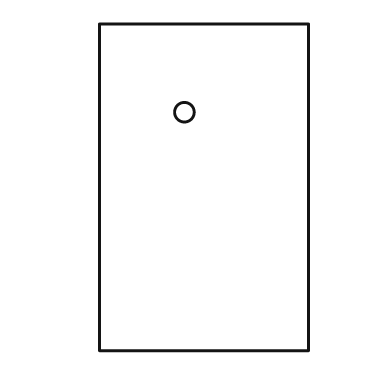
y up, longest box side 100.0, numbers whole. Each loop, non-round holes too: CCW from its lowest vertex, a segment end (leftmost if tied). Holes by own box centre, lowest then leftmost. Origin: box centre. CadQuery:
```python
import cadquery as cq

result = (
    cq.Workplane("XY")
    .moveTo(-32.0, -50.0)
    .lineTo(32.0, -50.0)
    .lineTo(32.0, 50.0)
    .lineTo(-32.0, 50.0)
    .close()
    .moveTo(-6.0, 23.0)
    .circle(3.0)
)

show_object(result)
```